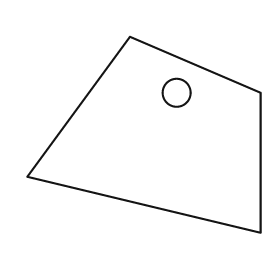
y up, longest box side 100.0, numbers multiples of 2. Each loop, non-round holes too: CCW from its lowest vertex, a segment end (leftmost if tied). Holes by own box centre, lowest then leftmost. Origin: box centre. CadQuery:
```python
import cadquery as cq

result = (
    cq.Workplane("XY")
    .moveTo(50.0, -42.0)
    .lineTo(50.0, 18.0)
    .lineTo(-6.0, 42.0)
    .lineTo(-50.0, -18.0)
    .close()
    .moveTo(14.0, 18.0)
    .circle(6.0)
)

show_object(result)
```